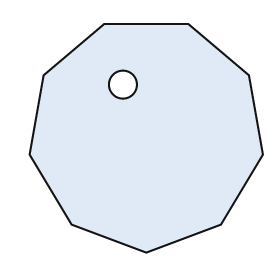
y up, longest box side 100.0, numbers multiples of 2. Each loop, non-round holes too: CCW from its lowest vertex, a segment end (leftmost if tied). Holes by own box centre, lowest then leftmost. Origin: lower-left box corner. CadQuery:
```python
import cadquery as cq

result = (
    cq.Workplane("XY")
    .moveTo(50.0, 0.0)
    .lineTo(82.0, 12.0)
    .lineTo(100.0, 42.0)
    .lineTo(94.0, 76.0)
    .lineTo(68.0, 98.0)
    .lineTo(32.0, 98.0)
    .lineTo(6.0, 76.0)
    .lineTo(0.0, 42.0)
    .lineTo(18.0, 12.0)
    .close()
    .moveTo(40.0, 72.0)
    .circle(6.0)
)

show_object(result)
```